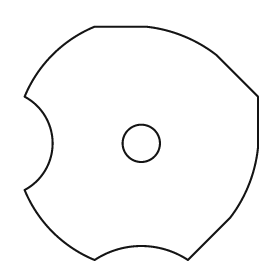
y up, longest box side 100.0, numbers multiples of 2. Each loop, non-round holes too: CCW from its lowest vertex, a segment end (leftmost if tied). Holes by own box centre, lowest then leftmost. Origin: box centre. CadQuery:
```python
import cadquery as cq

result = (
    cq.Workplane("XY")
    .moveTo(-20.0, -50.0)
    .threePointArc((0.0, -44.0), (20.0, -50.0))
    .lineTo(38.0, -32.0)
    .threePointArc((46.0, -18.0), (50.0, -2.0))
    .lineTo(50.0, 20.0)
    .lineTo(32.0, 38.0)
    .threePointArc((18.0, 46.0), (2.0, 50.0))
    .lineTo(-20.0, 50.0)
    .threePointArc((-38.0, 38.0), (-50.0, 20.0))
    .threePointArc((-38.0, 0.0), (-50.0, -20.0))
    .threePointArc((-38.0, -38.0), (-20.0, -50.0))
    .close()
    .moveTo(0.0, 0.0)
    .circle(8.0)
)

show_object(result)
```